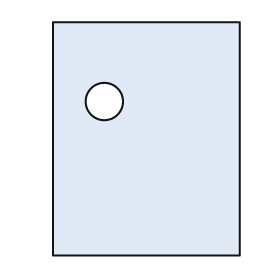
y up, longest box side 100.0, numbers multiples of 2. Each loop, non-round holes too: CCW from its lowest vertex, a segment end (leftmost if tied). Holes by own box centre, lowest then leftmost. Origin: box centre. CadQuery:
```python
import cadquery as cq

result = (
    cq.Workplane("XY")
    .moveTo(-40.0, -50.0)
    .lineTo(40.0, -50.0)
    .lineTo(40.0, 50.0)
    .lineTo(-40.0, 50.0)
    .close()
    .moveTo(-18.0, 16.0)
    .circle(8.0)
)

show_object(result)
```